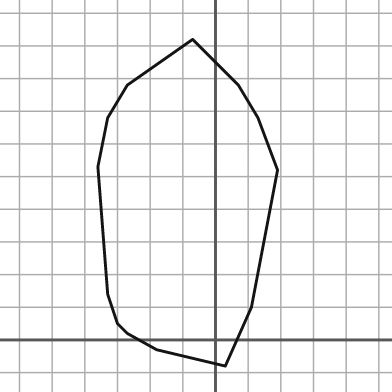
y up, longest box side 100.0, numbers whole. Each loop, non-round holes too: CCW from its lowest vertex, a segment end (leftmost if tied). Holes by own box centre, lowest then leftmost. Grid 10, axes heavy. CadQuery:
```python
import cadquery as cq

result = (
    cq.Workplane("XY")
    .moveTo(3.0, -8.0)
    .lineTo(11.0, 10.0)
    .lineTo(19.0, 52.0)
    .lineTo(13.0, 68.0)
    .lineTo(7.0, 78.0)
    .lineTo(-7.0, 92.0)
    .lineTo(-27.0, 78.0)
    .lineTo(-33.0, 68.0)
    .lineTo(-36.0, 53.0)
    .lineTo(-33.0, 14.0)
    .lineTo(-30.0, 5.0)
    .lineTo(-27.0, 2.0)
    .lineTo(-18.0, -3.0)
    .close()
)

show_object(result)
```